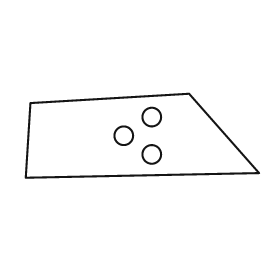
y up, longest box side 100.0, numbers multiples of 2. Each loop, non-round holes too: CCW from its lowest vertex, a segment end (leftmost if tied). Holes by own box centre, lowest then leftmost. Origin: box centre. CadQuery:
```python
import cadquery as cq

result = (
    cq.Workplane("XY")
    .moveTo(-50.0, -18.0)
    .lineTo(50.0, -16.0)
    .lineTo(20.0, 18.0)
    .lineTo(-48.0, 14.0)
    .close()
    .moveTo(4.0, -8.0)
    .circle(4.0)
    .moveTo(-8.0, 0.0)
    .circle(4.0)
    .moveTo(4.0, 8.0)
    .circle(4.0)
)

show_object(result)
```